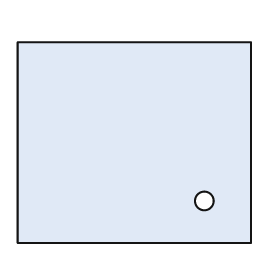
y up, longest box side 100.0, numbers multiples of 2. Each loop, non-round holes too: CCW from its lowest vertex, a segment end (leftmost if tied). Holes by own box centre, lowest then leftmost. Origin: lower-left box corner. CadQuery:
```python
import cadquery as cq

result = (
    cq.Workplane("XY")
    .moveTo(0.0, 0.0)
    .lineTo(100.0, 0.0)
    .lineTo(100.0, 86.0)
    .lineTo(0.0, 86.0)
    .close()
    .moveTo(80.0, 18.0)
    .circle(4.0)
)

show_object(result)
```